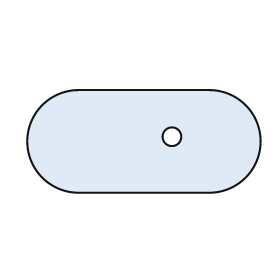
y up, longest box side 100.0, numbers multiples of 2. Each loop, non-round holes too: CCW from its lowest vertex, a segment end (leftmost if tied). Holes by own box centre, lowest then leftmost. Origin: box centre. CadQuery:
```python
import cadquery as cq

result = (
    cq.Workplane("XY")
    .moveTo(-28.0, -22.0)
    .lineTo(28.0, -22.0)
    .threePointArc((50.0, 0.0), (28.0, 22.0))
    .lineTo(-28.0, 22.0)
    .threePointArc((-50.0, 0.0), (-28.0, -22.0))
    .close()
    .moveTo(12.0, 2.0)
    .circle(4.0)
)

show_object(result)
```